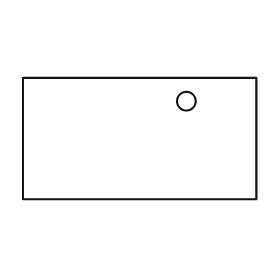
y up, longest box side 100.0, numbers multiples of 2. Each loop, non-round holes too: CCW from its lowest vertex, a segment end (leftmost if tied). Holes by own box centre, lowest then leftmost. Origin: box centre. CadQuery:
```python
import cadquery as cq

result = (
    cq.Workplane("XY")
    .moveTo(-50.0, -26.0)
    .lineTo(50.0, -26.0)
    .lineTo(50.0, 26.0)
    .lineTo(-50.0, 26.0)
    .close()
    .moveTo(20.0, 16.0)
    .circle(4.0)
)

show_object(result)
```